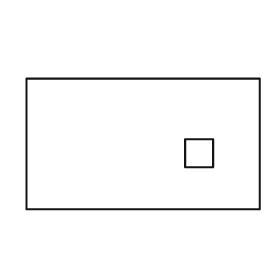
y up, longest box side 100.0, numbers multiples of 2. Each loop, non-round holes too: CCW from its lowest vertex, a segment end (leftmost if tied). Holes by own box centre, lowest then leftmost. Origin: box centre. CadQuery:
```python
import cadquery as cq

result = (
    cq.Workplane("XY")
    .moveTo(-50.0, -28.0)
    .lineTo(50.0, -28.0)
    .lineTo(50.0, 28.0)
    .lineTo(-50.0, 28.0)
    .close()
    .moveTo(18.0, -10.0)
    .lineTo(30.0, -10.0)
    .lineTo(30.0, 2.0)
    .lineTo(18.0, 2.0)
    .close()
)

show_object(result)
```